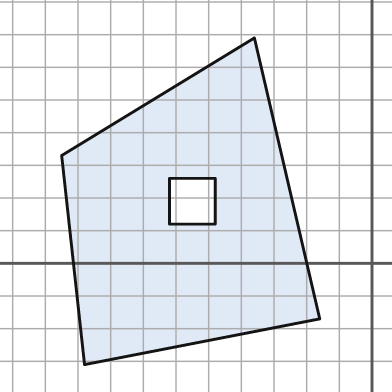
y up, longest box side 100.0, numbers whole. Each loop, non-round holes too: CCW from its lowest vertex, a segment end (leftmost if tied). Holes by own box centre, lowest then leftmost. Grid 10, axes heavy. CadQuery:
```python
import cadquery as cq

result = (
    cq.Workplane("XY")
    .moveTo(-88.0, -31.0)
    .lineTo(-16.0, -17.0)
    .lineTo(-36.0, 69.0)
    .lineTo(-95.0, 33.0)
    .close()
    .moveTo(-62.0, 12.0)
    .lineTo(-48.0, 12.0)
    .lineTo(-48.0, 26.0)
    .lineTo(-62.0, 26.0)
    .close()
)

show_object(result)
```